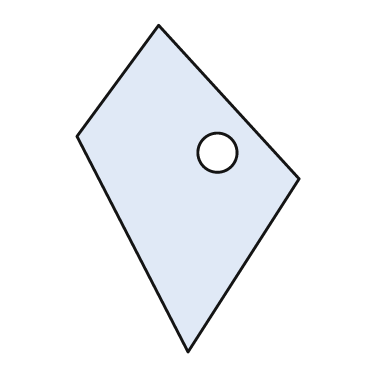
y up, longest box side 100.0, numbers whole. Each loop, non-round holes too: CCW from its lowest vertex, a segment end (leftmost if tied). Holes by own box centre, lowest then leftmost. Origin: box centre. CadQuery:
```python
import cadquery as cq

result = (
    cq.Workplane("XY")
    .moveTo(0.0, -50.0)
    .lineTo(34.0, 3.0)
    .lineTo(-9.0, 50.0)
    .lineTo(-34.0, 16.0)
    .close()
    .moveTo(9.0, 11.0)
    .circle(6.0)
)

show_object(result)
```